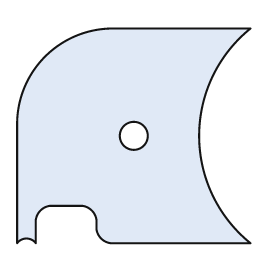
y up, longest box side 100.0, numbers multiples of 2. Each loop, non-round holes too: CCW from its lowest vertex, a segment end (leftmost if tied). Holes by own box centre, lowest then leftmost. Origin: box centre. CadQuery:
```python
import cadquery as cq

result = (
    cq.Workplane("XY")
    .moveTo(-50.0, -46.0)
    .threePointArc((-46.0, -44.0), (-42.0, -46.0))
    .lineTo(-42.0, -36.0)
    .threePointArc((-40.0, -32.0), (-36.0, -30.0))
    .lineTo(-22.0, -30.0)
    .threePointArc((-18.0, -32.0), (-16.0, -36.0))
    .lineTo(-16.0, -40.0)
    .threePointArc((-14.0, -44.0), (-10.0, -46.0))
    .lineTo(50.0, -46.0)
    .threePointArc((28.0, 0.0), (50.0, 46.0))
    .lineTo(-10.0, 46.0)
    .threePointArc((-38.0, 34.0), (-50.0, 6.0))
    .close()
    .moveTo(0.0, 0.0)
    .circle(6.0)
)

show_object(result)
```